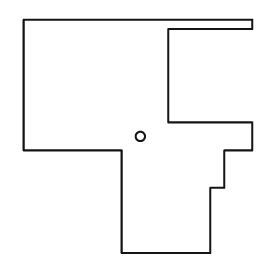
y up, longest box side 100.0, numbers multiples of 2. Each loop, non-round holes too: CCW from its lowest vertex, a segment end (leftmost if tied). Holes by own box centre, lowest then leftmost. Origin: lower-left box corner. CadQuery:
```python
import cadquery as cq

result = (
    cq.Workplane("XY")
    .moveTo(42.0, 0.0)
    .lineTo(80.0, 0.0)
    .lineTo(80.0, 28.0)
    .lineTo(86.0, 28.0)
    .lineTo(86.0, 44.0)
    .lineTo(98.0, 44.0)
    .lineTo(98.0, 56.0)
    .lineTo(62.0, 56.0)
    .lineTo(62.0, 96.0)
    .lineTo(98.0, 96.0)
    .lineTo(98.0, 100.0)
    .lineTo(0.0, 100.0)
    .lineTo(0.0, 44.0)
    .lineTo(42.0, 44.0)
    .close()
    .moveTo(50.0, 50.0)
    .circle(2.0)
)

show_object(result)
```